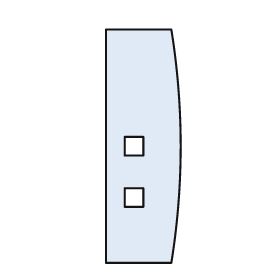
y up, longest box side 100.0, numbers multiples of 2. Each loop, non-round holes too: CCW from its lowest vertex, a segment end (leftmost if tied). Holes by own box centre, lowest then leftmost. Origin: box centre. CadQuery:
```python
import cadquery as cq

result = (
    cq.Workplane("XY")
    .moveTo(-16.0, -50.0)
    .lineTo(12.0, -50.0)
    .threePointArc((16.0, 0.0), (12.0, 50.0))
    .lineTo(-16.0, 50.0)
    .close()
    .moveTo(-8.0, -26.0)
    .lineTo(0.0, -26.0)
    .lineTo(0.0, -18.0)
    .lineTo(-8.0, -18.0)
    .close()
    .moveTo(-8.0, -4.0)
    .lineTo(0.0, -4.0)
    .lineTo(0.0, 4.0)
    .lineTo(-8.0, 4.0)
    .close()
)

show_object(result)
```